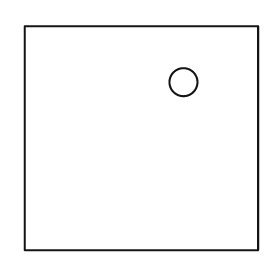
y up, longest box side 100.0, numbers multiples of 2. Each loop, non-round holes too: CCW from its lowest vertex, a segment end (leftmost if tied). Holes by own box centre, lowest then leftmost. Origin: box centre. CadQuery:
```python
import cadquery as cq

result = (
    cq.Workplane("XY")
    .moveTo(-50.0, -48.0)
    .lineTo(50.0, -48.0)
    .lineTo(50.0, 48.0)
    .lineTo(-50.0, 48.0)
    .close()
    .moveTo(18.0, 24.0)
    .circle(6.0)
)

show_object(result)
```